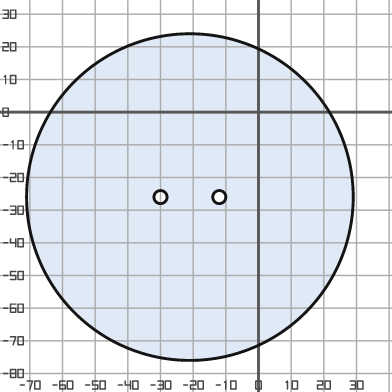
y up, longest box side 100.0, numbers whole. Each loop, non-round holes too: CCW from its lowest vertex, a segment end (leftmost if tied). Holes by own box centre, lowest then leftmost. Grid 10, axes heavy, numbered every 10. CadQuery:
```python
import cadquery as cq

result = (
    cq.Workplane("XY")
    .moveTo(-21.0, -26.0)
    .circle(50.0)
    .moveTo(-30.0, -26.0)
    .circle(2.0)
    .moveTo(-12.0, -26.0)
    .circle(2.0)
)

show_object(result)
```